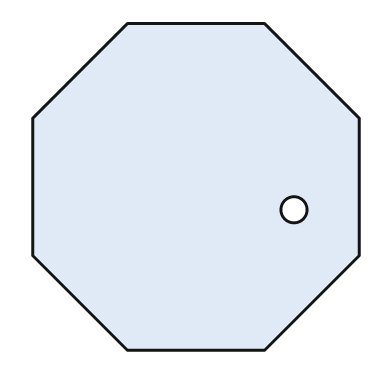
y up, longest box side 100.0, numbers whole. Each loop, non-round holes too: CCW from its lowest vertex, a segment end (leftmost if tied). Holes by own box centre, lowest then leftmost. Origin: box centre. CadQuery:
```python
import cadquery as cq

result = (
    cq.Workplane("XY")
    .moveTo(-21.0, -50.0)
    .lineTo(21.0, -50.0)
    .lineTo(50.0, -21.0)
    .lineTo(50.0, 21.0)
    .lineTo(21.0, 50.0)
    .lineTo(-21.0, 50.0)
    .lineTo(-50.0, 21.0)
    .lineTo(-50.0, -21.0)
    .close()
    .moveTo(30.0, -7.0)
    .circle(4.0)
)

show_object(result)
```